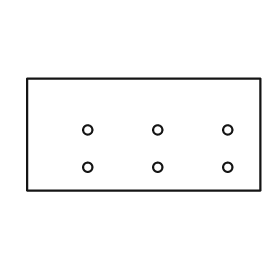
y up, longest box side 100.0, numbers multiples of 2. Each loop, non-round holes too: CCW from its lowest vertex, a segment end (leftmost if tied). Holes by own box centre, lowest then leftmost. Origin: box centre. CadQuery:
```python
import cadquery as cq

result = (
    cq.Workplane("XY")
    .moveTo(-50.0, -24.0)
    .lineTo(50.0, -24.0)
    .lineTo(50.0, 24.0)
    .lineTo(-50.0, 24.0)
    .close()
    .moveTo(-24.0, -14.0)
    .circle(2.0)
    .moveTo(6.0, -14.0)
    .circle(2.0)
    .moveTo(36.0, -14.0)
    .circle(2.0)
    .moveTo(-24.0, 2.0)
    .circle(2.0)
    .moveTo(6.0, 2.0)
    .circle(2.0)
    .moveTo(36.0, 2.0)
    .circle(2.0)
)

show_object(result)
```